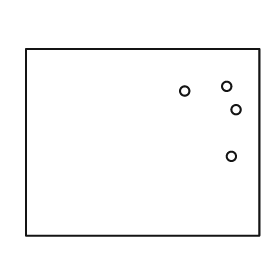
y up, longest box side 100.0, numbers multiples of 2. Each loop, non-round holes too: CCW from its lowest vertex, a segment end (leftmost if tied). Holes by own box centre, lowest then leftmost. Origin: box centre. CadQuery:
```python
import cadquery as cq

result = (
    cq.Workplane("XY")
    .moveTo(-50.0, -40.0)
    .lineTo(50.0, -40.0)
    .lineTo(50.0, 40.0)
    .lineTo(-50.0, 40.0)
    .close()
    .moveTo(38.0, -6.0)
    .circle(2.0)
    .moveTo(40.0, 14.0)
    .circle(2.0)
    .moveTo(18.0, 22.0)
    .circle(2.0)
    .moveTo(36.0, 24.0)
    .circle(2.0)
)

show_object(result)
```